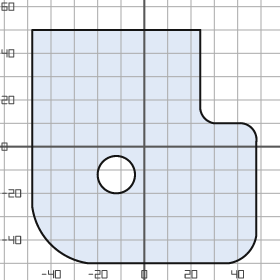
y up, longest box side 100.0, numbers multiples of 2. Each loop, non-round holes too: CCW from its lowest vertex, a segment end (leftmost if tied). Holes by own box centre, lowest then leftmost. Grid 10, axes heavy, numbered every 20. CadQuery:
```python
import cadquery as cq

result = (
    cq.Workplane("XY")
    .moveTo(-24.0, -50.0)
    .lineTo(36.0, -50.0)
    .threePointArc((44.0, -46.0), (48.0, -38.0))
    .lineTo(48.0, 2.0)
    .threePointArc((46.0, 8.0), (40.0, 10.0))
    .lineTo(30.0, 10.0)
    .threePointArc((26.0, 12.0), (24.0, 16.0))
    .lineTo(24.0, 50.0)
    .lineTo(-48.0, 50.0)
    .lineTo(-48.0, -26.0)
    .threePointArc((-40.0, -42.0), (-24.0, -50.0))
    .close()
    .moveTo(-12.0, -12.0)
    .circle(8.0)
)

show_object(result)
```